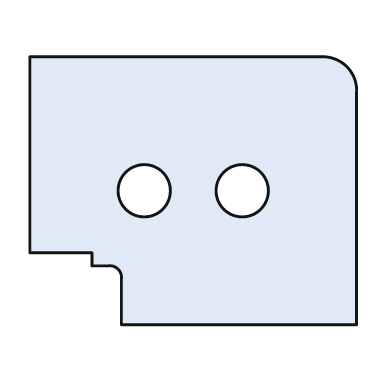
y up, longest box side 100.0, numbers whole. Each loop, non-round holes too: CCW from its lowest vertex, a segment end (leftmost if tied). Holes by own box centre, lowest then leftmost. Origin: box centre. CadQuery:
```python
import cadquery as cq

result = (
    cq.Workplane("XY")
    .moveTo(-22.0, -41.0)
    .lineTo(50.0, -41.0)
    .lineTo(50.0, 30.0)
    .threePointArc((47.0, 38.0), (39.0, 41.0))
    .lineTo(-50.0, 41.0)
    .lineTo(-50.0, -19.0)
    .lineTo(-31.0, -19.0)
    .lineTo(-31.0, -23.0)
    .lineTo(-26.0, -23.0)
    .threePointArc((-23.0, -24.0), (-22.0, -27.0))
    .close()
    .moveTo(-15.0, 0.0)
    .circle(8.0)
    .moveTo(15.0, 0.0)
    .circle(8.0)
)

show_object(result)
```